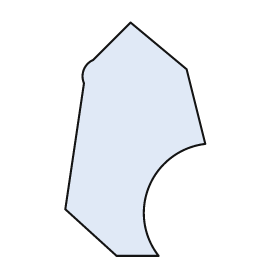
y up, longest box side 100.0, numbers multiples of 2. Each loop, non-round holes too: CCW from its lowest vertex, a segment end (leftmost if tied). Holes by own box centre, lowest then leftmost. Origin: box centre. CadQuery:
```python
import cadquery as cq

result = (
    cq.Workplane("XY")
    .moveTo(-8.0, -50.0)
    .lineTo(10.0, -50.0)
    .threePointArc((6.0, -20.0), (30.0, -2.0))
    .lineTo(22.0, 30.0)
    .lineTo(-2.0, 50.0)
    .lineTo(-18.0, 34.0)
    .threePointArc((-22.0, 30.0), (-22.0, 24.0))
    .lineTo(-30.0, -30.0)
    .close()
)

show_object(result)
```